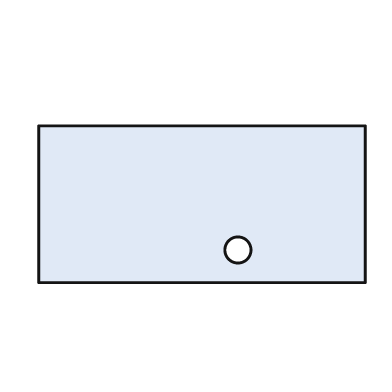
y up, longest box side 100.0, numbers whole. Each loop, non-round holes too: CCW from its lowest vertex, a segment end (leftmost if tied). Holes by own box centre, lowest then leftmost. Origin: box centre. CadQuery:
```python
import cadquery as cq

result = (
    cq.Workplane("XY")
    .moveTo(-50.0, -24.0)
    .lineTo(50.0, -24.0)
    .lineTo(50.0, 24.0)
    .lineTo(-50.0, 24.0)
    .close()
    .moveTo(11.0, -14.0)
    .circle(4.0)
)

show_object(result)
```